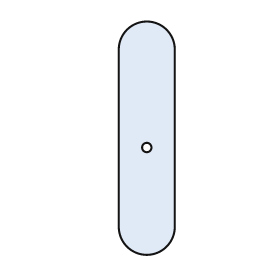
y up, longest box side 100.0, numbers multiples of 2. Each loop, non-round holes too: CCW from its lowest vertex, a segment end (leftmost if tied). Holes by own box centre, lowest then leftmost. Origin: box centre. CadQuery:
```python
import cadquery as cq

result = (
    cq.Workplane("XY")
    .moveTo(-12.0, -38.0)
    .threePointArc((0.0, -50.0), (12.0, -38.0))
    .lineTo(12.0, 38.0)
    .threePointArc((0.0, 50.0), (-12.0, 38.0))
    .close()
    .moveTo(0.0, -4.0)
    .circle(2.0)
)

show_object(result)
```